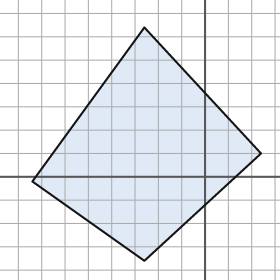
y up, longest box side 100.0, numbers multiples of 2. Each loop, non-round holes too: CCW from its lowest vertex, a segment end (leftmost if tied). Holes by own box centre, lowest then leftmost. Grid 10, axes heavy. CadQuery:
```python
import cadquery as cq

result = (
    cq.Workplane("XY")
    .moveTo(-26.0, -36.0)
    .lineTo(24.0, 10.0)
    .lineTo(-26.0, 64.0)
    .lineTo(-74.0, -2.0)
    .close()
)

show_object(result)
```